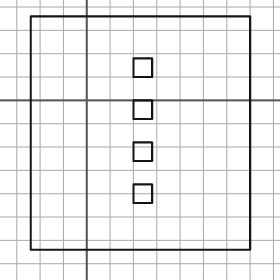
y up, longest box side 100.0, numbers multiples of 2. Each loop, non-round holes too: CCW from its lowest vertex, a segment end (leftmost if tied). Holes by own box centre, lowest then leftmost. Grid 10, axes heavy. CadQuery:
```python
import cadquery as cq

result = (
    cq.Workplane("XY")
    .moveTo(-24.0, -64.0)
    .lineTo(70.0, -64.0)
    .lineTo(70.0, 36.0)
    .lineTo(-24.0, 36.0)
    .close()
    .moveTo(20.0, -44.0)
    .lineTo(28.0, -44.0)
    .lineTo(28.0, -36.0)
    .lineTo(20.0, -36.0)
    .close()
    .moveTo(20.0, -26.0)
    .lineTo(28.0, -26.0)
    .lineTo(28.0, -18.0)
    .lineTo(20.0, -18.0)
    .close()
    .moveTo(20.0, -8.0)
    .lineTo(28.0, -8.0)
    .lineTo(28.0, 0.0)
    .lineTo(20.0, 0.0)
    .close()
    .moveTo(20.0, 10.0)
    .lineTo(28.0, 10.0)
    .lineTo(28.0, 18.0)
    .lineTo(20.0, 18.0)
    .close()
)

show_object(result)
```